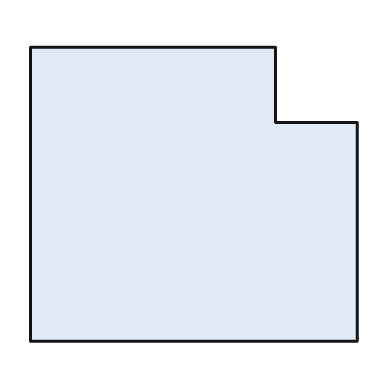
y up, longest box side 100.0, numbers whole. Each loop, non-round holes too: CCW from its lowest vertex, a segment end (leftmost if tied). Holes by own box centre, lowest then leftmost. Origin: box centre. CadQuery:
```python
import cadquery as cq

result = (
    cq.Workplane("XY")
    .moveTo(-50.0, -45.0)
    .lineTo(50.0, -45.0)
    .lineTo(50.0, 22.0)
    .lineTo(25.0, 22.0)
    .lineTo(25.0, 45.0)
    .lineTo(-50.0, 45.0)
    .close()
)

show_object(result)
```